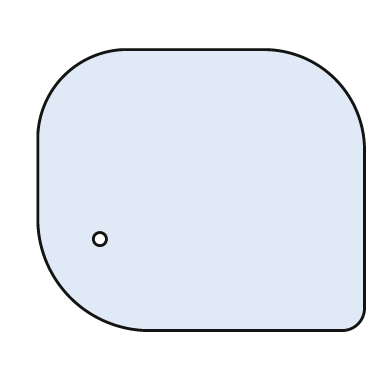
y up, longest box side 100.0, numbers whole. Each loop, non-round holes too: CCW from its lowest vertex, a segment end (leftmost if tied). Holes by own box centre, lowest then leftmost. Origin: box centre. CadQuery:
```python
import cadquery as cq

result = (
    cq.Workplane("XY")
    .moveTo(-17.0, -43.0)
    .lineTo(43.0, -43.0)
    .threePointArc((48.0, -41.0), (50.0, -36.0))
    .lineTo(50.0, 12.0)
    .threePointArc((41.0, 34.0), (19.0, 43.0))
    .lineTo(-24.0, 43.0)
    .threePointArc((-42.0, 35.0), (-50.0, 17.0))
    .lineTo(-50.0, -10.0)
    .threePointArc((-40.0, -33.0), (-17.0, -43.0))
    .close()
    .moveTo(-31.0, -15.0)
    .circle(2.0)
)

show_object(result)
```